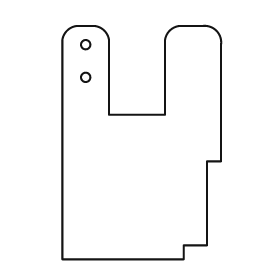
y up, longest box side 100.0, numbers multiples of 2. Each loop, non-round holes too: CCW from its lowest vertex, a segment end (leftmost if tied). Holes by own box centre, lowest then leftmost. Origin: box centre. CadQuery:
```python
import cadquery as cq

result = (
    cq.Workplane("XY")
    .moveTo(-34.0, -50.0)
    .lineTo(18.0, -50.0)
    .lineTo(18.0, -44.0)
    .lineTo(28.0, -44.0)
    .lineTo(28.0, -8.0)
    .lineTo(34.0, -8.0)
    .lineTo(34.0, 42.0)
    .threePointArc((32.0, 48.0), (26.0, 50.0))
    .lineTo(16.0, 50.0)
    .threePointArc((12.0, 48.0), (10.0, 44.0))
    .lineTo(10.0, 12.0)
    .lineTo(-14.0, 12.0)
    .lineTo(-14.0, 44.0)
    .threePointArc((-16.0, 48.0), (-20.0, 50.0))
    .lineTo(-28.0, 50.0)
    .threePointArc((-32.0, 48.0), (-34.0, 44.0))
    .close()
    .moveTo(-24.0, 28.0)
    .circle(2.0)
    .moveTo(-24.0, 42.0)
    .circle(2.0)
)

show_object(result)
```